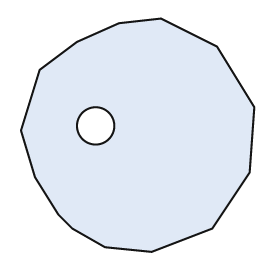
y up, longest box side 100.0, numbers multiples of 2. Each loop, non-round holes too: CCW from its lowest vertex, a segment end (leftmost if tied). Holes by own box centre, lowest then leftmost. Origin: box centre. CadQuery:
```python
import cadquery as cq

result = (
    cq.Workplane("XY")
    .moveTo(6.0, -50.0)
    .lineTo(32.0, -40.0)
    .lineTo(48.0, -16.0)
    .lineTo(50.0, 12.0)
    .lineTo(34.0, 38.0)
    .lineTo(10.0, 50.0)
    .lineTo(-8.0, 48.0)
    .lineTo(-26.0, 40.0)
    .lineTo(-42.0, 28.0)
    .lineTo(-50.0, 2.0)
    .lineTo(-44.0, -18.0)
    .lineTo(-34.0, -34.0)
    .lineTo(-28.0, -40.0)
    .lineTo(-14.0, -48.0)
    .close()
    .moveTo(-18.0, 4.0)
    .circle(8.0)
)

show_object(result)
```